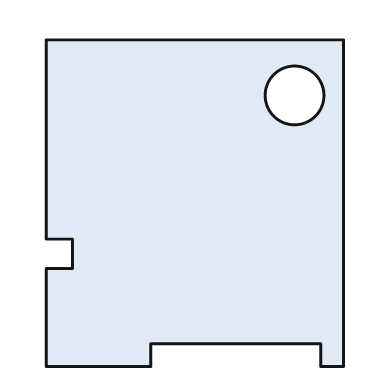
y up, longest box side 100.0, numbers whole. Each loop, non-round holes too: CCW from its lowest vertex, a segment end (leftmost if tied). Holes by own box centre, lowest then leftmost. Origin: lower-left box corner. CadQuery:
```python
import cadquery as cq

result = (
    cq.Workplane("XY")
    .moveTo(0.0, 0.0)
    .lineTo(32.0, 0.0)
    .lineTo(32.0, 7.0)
    .lineTo(84.0, 7.0)
    .lineTo(84.0, 0.0)
    .lineTo(91.0, 0.0)
    .lineTo(91.0, 100.0)
    .lineTo(0.0, 100.0)
    .lineTo(0.0, 39.0)
    .lineTo(8.0, 39.0)
    .lineTo(8.0, 30.0)
    .lineTo(0.0, 30.0)
    .close()
    .moveTo(76.0, 83.0)
    .circle(9.0)
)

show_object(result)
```